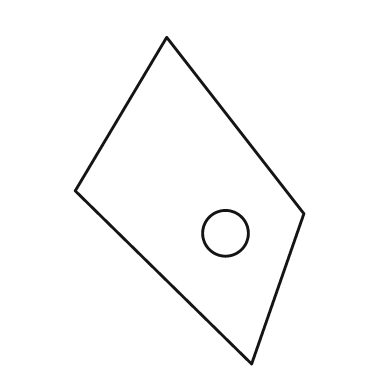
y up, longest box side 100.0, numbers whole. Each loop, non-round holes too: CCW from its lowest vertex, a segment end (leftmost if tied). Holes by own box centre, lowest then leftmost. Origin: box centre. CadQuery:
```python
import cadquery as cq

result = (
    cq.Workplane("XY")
    .moveTo(19.0, -50.0)
    .lineTo(35.0, -4.0)
    .lineTo(-7.0, 50.0)
    .lineTo(-35.0, 3.0)
    .close()
    .moveTo(11.0, -10.0)
    .circle(7.0)
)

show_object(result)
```